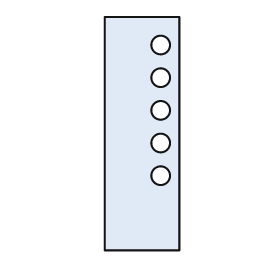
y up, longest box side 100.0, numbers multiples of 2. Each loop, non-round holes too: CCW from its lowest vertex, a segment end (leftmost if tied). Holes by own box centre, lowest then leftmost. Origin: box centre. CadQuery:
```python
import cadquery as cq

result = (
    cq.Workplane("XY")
    .moveTo(-16.0, -50.0)
    .lineTo(16.0, -50.0)
    .lineTo(16.0, 50.0)
    .lineTo(-16.0, 50.0)
    .close()
    .moveTo(8.0, -18.0)
    .circle(4.0)
    .moveTo(8.0, -4.0)
    .circle(4.0)
    .moveTo(8.0, 10.0)
    .circle(4.0)
    .moveTo(8.0, 24.0)
    .circle(4.0)
    .moveTo(8.0, 38.0)
    .circle(4.0)
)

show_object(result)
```